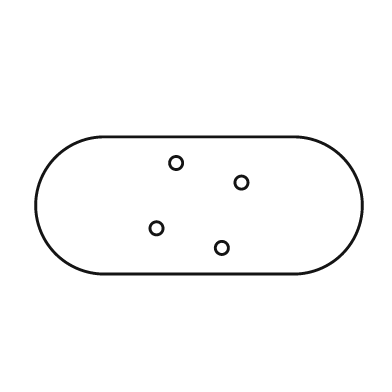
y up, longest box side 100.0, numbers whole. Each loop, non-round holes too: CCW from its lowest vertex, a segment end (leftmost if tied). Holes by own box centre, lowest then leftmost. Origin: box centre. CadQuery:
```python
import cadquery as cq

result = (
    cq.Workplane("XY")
    .moveTo(-29.0, -21.0)
    .lineTo(29.0, -21.0)
    .threePointArc((50.0, 0.0), (29.0, 21.0))
    .lineTo(-29.0, 21.0)
    .threePointArc((-50.0, 0.0), (-29.0, -21.0))
    .close()
    .moveTo(7.0, -13.0)
    .circle(2.0)
    .moveTo(-13.0, -7.0)
    .circle(2.0)
    .moveTo(13.0, 7.0)
    .circle(2.0)
    .moveTo(-7.0, 13.0)
    .circle(2.0)
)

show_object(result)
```